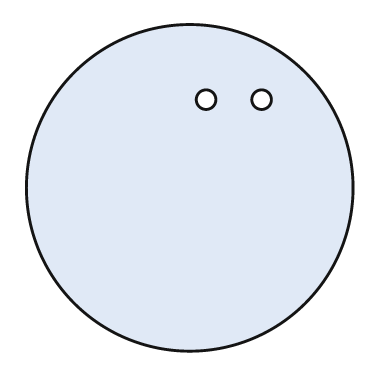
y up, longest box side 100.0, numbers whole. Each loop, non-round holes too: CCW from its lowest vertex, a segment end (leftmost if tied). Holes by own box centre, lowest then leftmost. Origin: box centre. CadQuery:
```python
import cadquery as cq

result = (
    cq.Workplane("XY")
    .moveTo(0.0, 0.0)
    .circle(50.0)
    .moveTo(5.0, 27.0)
    .circle(3.0)
    .moveTo(22.0, 27.0)
    .circle(3.0)
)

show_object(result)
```